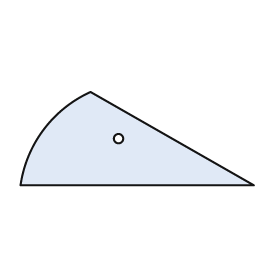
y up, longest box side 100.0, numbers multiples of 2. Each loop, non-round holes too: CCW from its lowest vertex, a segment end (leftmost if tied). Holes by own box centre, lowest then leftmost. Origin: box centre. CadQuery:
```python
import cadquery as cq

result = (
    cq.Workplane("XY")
    .moveTo(-50.0, -20.0)
    .lineTo(50.0, -20.0)
    .lineTo(-20.0, 20.0)
    .threePointArc((-40.0, 4.0), (-50.0, -20.0))
    .close()
    .moveTo(-8.0, 0.0)
    .circle(2.0)
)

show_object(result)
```